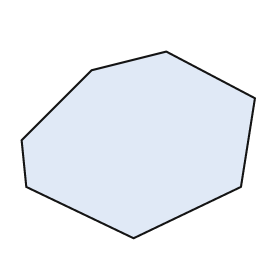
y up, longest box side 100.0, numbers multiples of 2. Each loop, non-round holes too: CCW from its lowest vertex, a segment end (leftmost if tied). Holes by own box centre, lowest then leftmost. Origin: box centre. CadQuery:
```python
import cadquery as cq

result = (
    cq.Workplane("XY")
    .moveTo(-2.0, -40.0)
    .lineTo(44.0, -18.0)
    .lineTo(50.0, 20.0)
    .lineTo(12.0, 40.0)
    .lineTo(-20.0, 32.0)
    .lineTo(-50.0, 2.0)
    .lineTo(-48.0, -18.0)
    .close()
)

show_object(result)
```